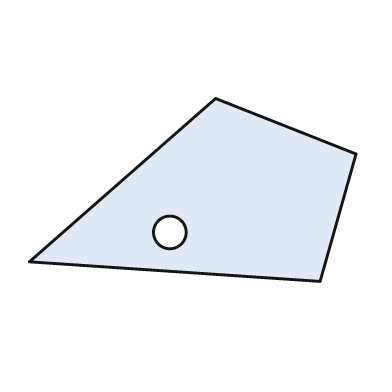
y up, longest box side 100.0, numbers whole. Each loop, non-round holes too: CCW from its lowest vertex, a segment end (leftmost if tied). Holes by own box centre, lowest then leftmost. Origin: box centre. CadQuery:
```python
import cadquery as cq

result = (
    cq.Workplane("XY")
    .moveTo(39.0, -28.0)
    .lineTo(50.0, 11.0)
    .lineTo(7.0, 28.0)
    .lineTo(-50.0, -22.0)
    .close()
    .moveTo(-7.0, -13.0)
    .circle(5.0)
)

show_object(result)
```